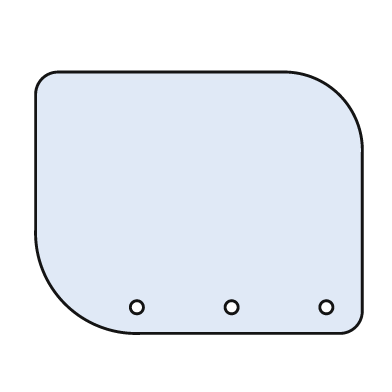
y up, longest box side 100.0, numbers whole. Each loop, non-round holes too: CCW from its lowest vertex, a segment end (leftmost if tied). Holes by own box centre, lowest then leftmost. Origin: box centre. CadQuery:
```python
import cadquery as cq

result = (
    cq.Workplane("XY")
    .moveTo(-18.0, -40.0)
    .lineTo(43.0, -40.0)
    .threePointArc((48.0, -38.0), (50.0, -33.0))
    .lineTo(50.0, 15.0)
    .threePointArc((43.0, 33.0), (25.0, 40.0))
    .lineTo(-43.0, 40.0)
    .threePointArc((-48.0, 38.0), (-50.0, 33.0))
    .lineTo(-50.0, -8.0)
    .threePointArc((-41.0, -31.0), (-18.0, -40.0))
    .close()
    .moveTo(-19.0, -32.0)
    .circle(2.0)
    .moveTo(10.0, -32.0)
    .circle(2.0)
    .moveTo(39.0, -32.0)
    .circle(2.0)
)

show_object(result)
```